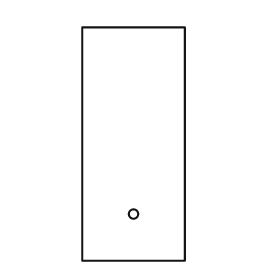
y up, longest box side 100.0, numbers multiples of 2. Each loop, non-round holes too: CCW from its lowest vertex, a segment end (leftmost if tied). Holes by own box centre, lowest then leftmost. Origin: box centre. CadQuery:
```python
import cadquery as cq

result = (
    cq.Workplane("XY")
    .moveTo(-22.0, -50.0)
    .lineTo(22.0, -50.0)
    .lineTo(22.0, 50.0)
    .lineTo(-22.0, 50.0)
    .close()
    .moveTo(0.0, -30.0)
    .circle(2.0)
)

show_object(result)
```